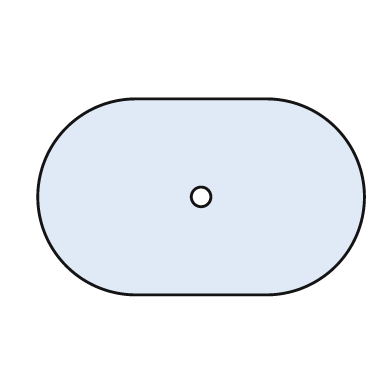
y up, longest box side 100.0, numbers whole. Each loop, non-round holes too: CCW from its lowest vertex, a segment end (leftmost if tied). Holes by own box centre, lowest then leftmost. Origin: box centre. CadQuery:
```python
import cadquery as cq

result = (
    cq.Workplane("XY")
    .moveTo(-20.0, -30.0)
    .lineTo(20.0, -30.0)
    .threePointArc((50.0, 0.0), (20.0, 30.0))
    .lineTo(-20.0, 30.0)
    .threePointArc((-50.0, 0.0), (-20.0, -30.0))
    .close()
    .moveTo(0.0, 0.0)
    .circle(3.0)
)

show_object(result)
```